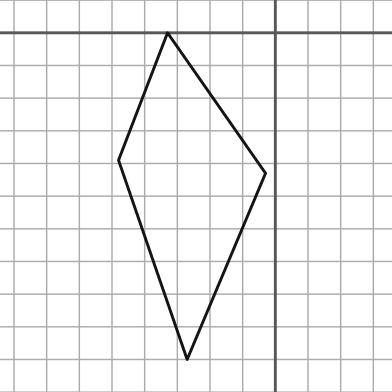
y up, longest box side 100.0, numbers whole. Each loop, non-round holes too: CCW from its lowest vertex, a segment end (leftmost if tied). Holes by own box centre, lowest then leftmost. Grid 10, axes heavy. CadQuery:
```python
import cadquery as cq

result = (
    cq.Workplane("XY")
    .moveTo(-27.0, -100.0)
    .lineTo(-3.0, -43.0)
    .lineTo(-33.0, 0.0)
    .lineTo(-48.0, -39.0)
    .close()
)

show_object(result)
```